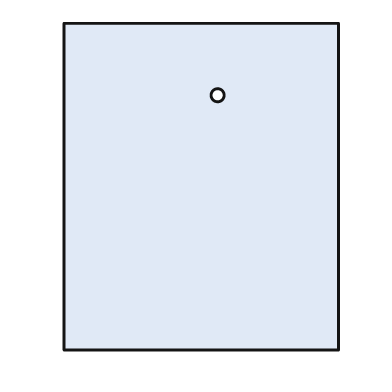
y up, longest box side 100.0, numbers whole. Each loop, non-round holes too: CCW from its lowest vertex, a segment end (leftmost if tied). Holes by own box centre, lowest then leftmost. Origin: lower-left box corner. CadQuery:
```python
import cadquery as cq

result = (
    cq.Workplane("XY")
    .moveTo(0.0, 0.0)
    .lineTo(84.0, 0.0)
    .lineTo(84.0, 100.0)
    .lineTo(0.0, 100.0)
    .close()
    .moveTo(47.0, 78.0)
    .circle(2.0)
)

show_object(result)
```